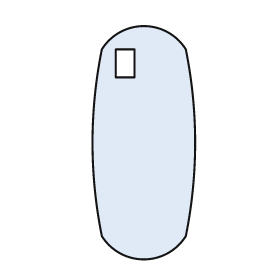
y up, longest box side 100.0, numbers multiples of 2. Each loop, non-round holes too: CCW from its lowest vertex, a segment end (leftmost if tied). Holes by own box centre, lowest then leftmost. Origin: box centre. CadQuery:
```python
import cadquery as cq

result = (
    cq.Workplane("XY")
    .moveTo(-18.0, -40.0)
    .threePointArc((0.0, -50.0), (18.0, -40.0))
    .threePointArc((22.0, 0.0), (18.0, 40.0))
    .threePointArc((0.0, 50.0), (-18.0, 40.0))
    .threePointArc((-22.0, 0.0), (-18.0, -40.0))
    .close()
    .moveTo(-12.0, 28.0)
    .lineTo(-4.0, 28.0)
    .lineTo(-4.0, 40.0)
    .lineTo(-12.0, 40.0)
    .close()
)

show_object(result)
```